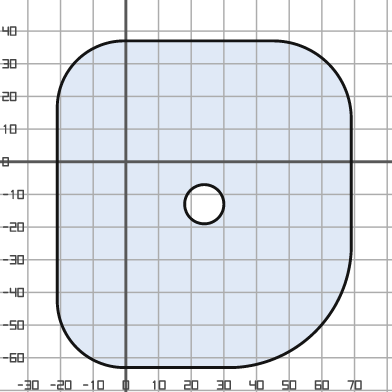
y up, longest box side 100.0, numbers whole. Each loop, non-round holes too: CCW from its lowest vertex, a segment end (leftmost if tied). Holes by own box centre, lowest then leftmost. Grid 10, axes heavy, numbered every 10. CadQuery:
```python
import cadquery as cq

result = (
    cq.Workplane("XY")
    .moveTo(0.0, -63.0)
    .lineTo(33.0, -63.0)
    .threePointArc((58.0, -52.0), (69.0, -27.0))
    .lineTo(69.0, 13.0)
    .threePointArc((62.0, 30.0), (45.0, 37.0))
    .lineTo(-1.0, 37.0)
    .threePointArc((-15.0, 31.0), (-21.0, 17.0))
    .lineTo(-21.0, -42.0)
    .threePointArc((-15.0, -57.0), (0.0, -63.0))
    .close()
    .moveTo(24.0, -13.0)
    .circle(6.0)
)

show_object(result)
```